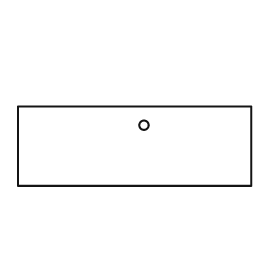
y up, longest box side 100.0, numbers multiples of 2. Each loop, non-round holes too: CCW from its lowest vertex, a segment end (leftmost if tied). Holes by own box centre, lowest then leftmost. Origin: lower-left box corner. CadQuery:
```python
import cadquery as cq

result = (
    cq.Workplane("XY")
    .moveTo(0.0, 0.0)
    .lineTo(100.0, 0.0)
    .lineTo(100.0, 34.0)
    .lineTo(0.0, 34.0)
    .close()
    .moveTo(54.0, 26.0)
    .circle(2.0)
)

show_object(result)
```